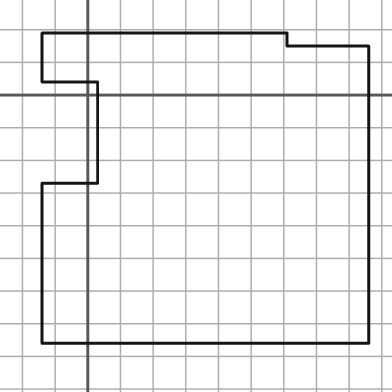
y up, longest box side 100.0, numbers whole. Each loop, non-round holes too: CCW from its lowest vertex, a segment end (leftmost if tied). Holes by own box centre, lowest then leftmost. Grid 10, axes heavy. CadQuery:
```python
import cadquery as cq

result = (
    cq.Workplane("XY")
    .moveTo(-14.0, -76.0)
    .lineTo(86.0, -76.0)
    .lineTo(86.0, 15.0)
    .lineTo(61.0, 15.0)
    .lineTo(61.0, 19.0)
    .lineTo(-14.0, 19.0)
    .lineTo(-14.0, 4.0)
    .lineTo(3.0, 4.0)
    .lineTo(3.0, -27.0)
    .lineTo(-14.0, -27.0)
    .close()
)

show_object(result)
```